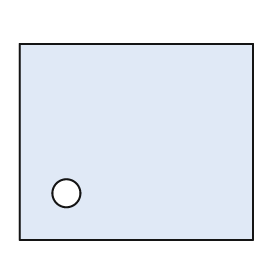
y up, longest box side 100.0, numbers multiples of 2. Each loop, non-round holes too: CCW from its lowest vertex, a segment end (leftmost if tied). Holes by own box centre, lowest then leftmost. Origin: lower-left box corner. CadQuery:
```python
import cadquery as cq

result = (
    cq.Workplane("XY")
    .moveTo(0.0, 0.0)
    .lineTo(100.0, 0.0)
    .lineTo(100.0, 84.0)
    .lineTo(0.0, 84.0)
    .close()
    .moveTo(20.0, 20.0)
    .circle(6.0)
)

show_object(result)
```